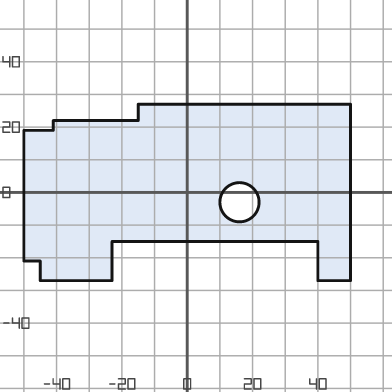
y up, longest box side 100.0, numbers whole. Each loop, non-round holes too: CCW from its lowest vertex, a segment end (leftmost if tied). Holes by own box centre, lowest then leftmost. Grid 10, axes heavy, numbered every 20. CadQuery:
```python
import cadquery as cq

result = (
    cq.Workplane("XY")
    .moveTo(-45.0, -27.0)
    .lineTo(-23.0, -27.0)
    .lineTo(-23.0, -15.0)
    .lineTo(40.0, -15.0)
    .lineTo(40.0, -27.0)
    .lineTo(50.0, -27.0)
    .lineTo(50.0, 27.0)
    .lineTo(-15.0, 27.0)
    .lineTo(-15.0, 22.0)
    .lineTo(-41.0, 22.0)
    .lineTo(-41.0, 19.0)
    .lineTo(-50.0, 19.0)
    .lineTo(-50.0, -21.0)
    .lineTo(-45.0, -21.0)
    .close()
    .moveTo(16.0, -3.0)
    .circle(6.0)
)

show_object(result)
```